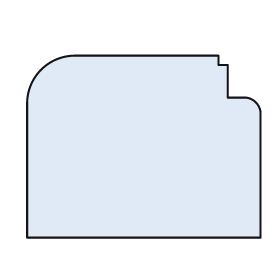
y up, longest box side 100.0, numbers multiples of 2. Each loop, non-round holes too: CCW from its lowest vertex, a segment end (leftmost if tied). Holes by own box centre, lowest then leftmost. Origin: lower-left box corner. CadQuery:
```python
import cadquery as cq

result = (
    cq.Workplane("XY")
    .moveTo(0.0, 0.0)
    .lineTo(100.0, 0.0)
    .lineTo(100.0, 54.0)
    .threePointArc((98.0, 58.0), (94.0, 60.0))
    .lineTo(86.0, 60.0)
    .lineTo(86.0, 74.0)
    .lineTo(82.0, 74.0)
    .lineTo(82.0, 78.0)
    .lineTo(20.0, 78.0)
    .threePointArc((6.0, 72.0), (0.0, 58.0))
    .close()
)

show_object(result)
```